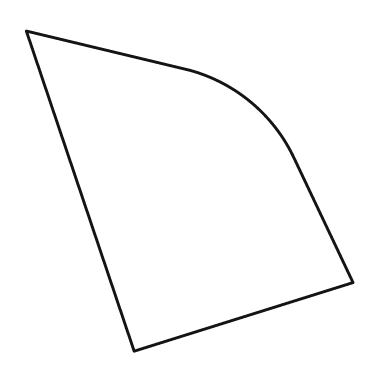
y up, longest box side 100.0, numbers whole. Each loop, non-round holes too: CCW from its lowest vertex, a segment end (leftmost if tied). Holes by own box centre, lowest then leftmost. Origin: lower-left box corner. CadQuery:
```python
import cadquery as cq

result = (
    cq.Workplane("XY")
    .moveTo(33.0, 0.0)
    .lineTo(100.0, 21.0)
    .lineTo(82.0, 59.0)
    .threePointArc((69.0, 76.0), (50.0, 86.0))
    .lineTo(0.0, 98.0)
    .close()
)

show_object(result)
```